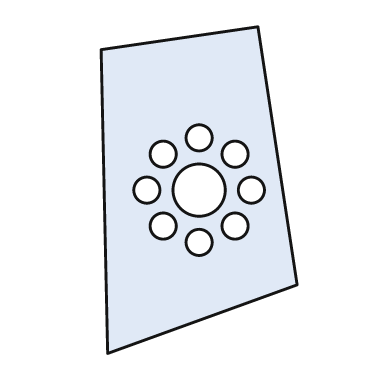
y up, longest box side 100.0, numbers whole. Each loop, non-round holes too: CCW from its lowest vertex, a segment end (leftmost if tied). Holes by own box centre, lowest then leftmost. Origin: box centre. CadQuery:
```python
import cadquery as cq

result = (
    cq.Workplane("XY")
    .moveTo(-28.0, -50.0)
    .lineTo(30.0, -29.0)
    .lineTo(18.0, 50.0)
    .lineTo(-30.0, 43.0)
    .close()
    .moveTo(0.0, -16.0)
    .circle(4.0)
    .moveTo(-11.0, -11.0)
    .circle(4.0)
    .moveTo(11.0, -11.0)
    .circle(4.0)
    .moveTo(-16.0, 0.0)
    .circle(4.0)
    .moveTo(0.0, 0.0)
    .circle(8.0)
    .moveTo(16.0, 0.0)
    .circle(4.0)
    .moveTo(-11.0, 11.0)
    .circle(4.0)
    .moveTo(11.0, 11.0)
    .circle(4.0)
    .moveTo(0.0, 16.0)
    .circle(4.0)
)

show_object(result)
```